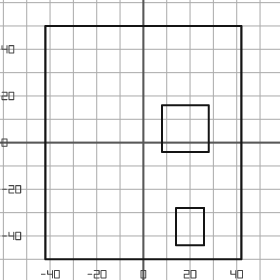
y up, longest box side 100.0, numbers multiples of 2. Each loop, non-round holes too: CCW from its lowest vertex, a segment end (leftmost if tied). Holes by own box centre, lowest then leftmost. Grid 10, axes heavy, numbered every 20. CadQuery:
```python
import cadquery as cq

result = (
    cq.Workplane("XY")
    .moveTo(-42.0, -50.0)
    .lineTo(42.0, -50.0)
    .lineTo(42.0, 50.0)
    .lineTo(-42.0, 50.0)
    .close()
    .moveTo(14.0, -44.0)
    .lineTo(26.0, -44.0)
    .lineTo(26.0, -28.0)
    .lineTo(14.0, -28.0)
    .close()
    .moveTo(8.0, -4.0)
    .lineTo(28.0, -4.0)
    .lineTo(28.0, 16.0)
    .lineTo(8.0, 16.0)
    .close()
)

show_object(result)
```